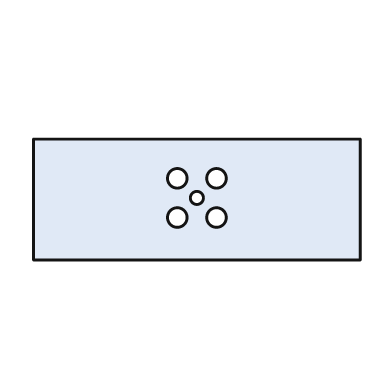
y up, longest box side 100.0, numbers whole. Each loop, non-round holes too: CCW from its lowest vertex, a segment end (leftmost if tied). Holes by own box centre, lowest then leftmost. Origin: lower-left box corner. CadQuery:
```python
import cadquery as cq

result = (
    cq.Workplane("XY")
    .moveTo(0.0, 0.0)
    .lineTo(100.0, 0.0)
    .lineTo(100.0, 37.0)
    .lineTo(0.0, 37.0)
    .close()
    .moveTo(44.0, 13.0)
    .circle(3.0)
    .moveTo(56.0, 13.0)
    .circle(3.0)
    .moveTo(50.0, 19.0)
    .circle(2.0)
    .moveTo(44.0, 25.0)
    .circle(3.0)
    .moveTo(56.0, 25.0)
    .circle(3.0)
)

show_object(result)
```